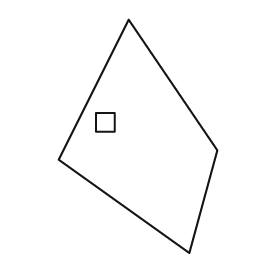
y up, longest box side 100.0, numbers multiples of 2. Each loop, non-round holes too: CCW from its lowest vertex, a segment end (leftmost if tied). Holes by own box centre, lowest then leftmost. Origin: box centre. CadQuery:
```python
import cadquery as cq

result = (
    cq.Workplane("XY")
    .moveTo(22.0, -50.0)
    .lineTo(34.0, -6.0)
    .lineTo(-4.0, 50.0)
    .lineTo(-34.0, -10.0)
    .close()
    .moveTo(-18.0, 2.0)
    .lineTo(-10.0, 2.0)
    .lineTo(-10.0, 10.0)
    .lineTo(-18.0, 10.0)
    .close()
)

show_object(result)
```